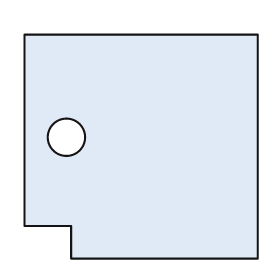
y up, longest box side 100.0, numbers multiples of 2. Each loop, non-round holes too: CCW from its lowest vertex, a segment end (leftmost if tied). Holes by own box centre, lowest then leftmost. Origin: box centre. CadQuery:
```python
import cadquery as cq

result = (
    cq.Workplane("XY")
    .moveTo(-30.0, -48.0)
    .lineTo(50.0, -48.0)
    .lineTo(50.0, 48.0)
    .lineTo(-50.0, 48.0)
    .lineTo(-50.0, -34.0)
    .lineTo(-30.0, -34.0)
    .close()
    .moveTo(-32.0, 4.0)
    .circle(8.0)
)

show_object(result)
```